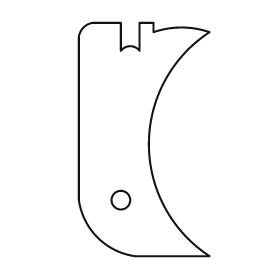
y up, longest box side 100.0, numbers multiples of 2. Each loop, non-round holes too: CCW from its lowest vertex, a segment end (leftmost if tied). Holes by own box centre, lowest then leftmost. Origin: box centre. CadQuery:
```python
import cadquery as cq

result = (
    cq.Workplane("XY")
    .moveTo(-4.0, -50.0)
    .lineTo(28.0, -50.0)
    .threePointArc((2.0, -2.0), (28.0, 46.0))
    .threePointArc((16.0, 48.0), (4.0, 46.0))
    .lineTo(4.0, 50.0)
    .lineTo(-2.0, 50.0)
    .lineTo(-2.0, 38.0)
    .threePointArc((-6.0, 40.0), (-10.0, 38.0))
    .lineTo(-10.0, 50.0)
    .lineTo(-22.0, 50.0)
    .threePointArc((-26.0, 48.0), (-28.0, 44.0))
    .lineTo(-28.0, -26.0)
    .threePointArc((-20.0, -42.0), (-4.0, -50.0))
    .close()
    .moveTo(-10.0, -26.0)
    .circle(4.0)
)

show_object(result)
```